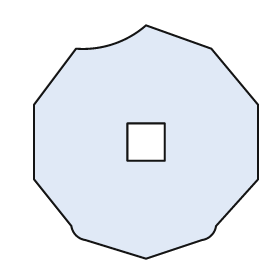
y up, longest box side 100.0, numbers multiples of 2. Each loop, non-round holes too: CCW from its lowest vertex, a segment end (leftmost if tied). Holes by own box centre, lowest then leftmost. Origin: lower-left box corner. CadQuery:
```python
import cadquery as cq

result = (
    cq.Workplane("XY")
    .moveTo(48.0, 0.0)
    .lineTo(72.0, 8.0)
    .threePointArc((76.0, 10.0), (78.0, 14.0))
    .lineTo(96.0, 34.0)
    .lineTo(96.0, 66.0)
    .lineTo(76.0, 90.0)
    .lineTo(48.0, 100.0)
    .threePointArc((34.0, 92.0), (18.0, 90.0))
    .lineTo(0.0, 66.0)
    .lineTo(0.0, 34.0)
    .lineTo(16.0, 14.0)
    .threePointArc((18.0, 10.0), (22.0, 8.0))
    .close()
    .moveTo(40.0, 42.0)
    .lineTo(56.0, 42.0)
    .lineTo(56.0, 58.0)
    .lineTo(40.0, 58.0)
    .close()
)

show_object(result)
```